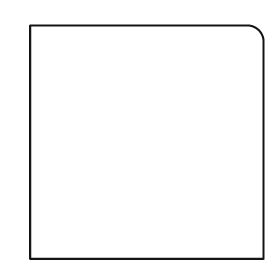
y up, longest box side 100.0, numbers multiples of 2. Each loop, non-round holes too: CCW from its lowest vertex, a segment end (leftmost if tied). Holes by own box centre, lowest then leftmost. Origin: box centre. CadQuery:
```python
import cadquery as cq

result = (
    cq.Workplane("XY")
    .moveTo(-50.0, -50.0)
    .lineTo(50.0, -50.0)
    .lineTo(50.0, 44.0)
    .threePointArc((48.0, 48.0), (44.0, 50.0))
    .lineTo(-50.0, 50.0)
    .close()
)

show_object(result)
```